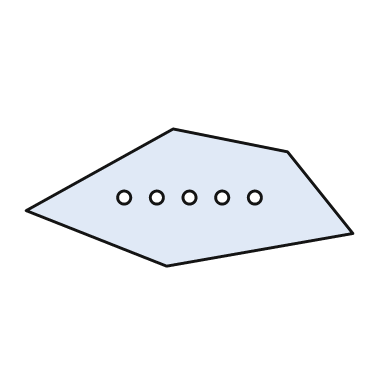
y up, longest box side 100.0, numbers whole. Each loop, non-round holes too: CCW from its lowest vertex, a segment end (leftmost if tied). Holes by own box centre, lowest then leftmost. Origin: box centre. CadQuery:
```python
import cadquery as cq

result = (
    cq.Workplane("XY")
    .moveTo(-7.0, -21.0)
    .lineTo(50.0, -11.0)
    .lineTo(30.0, 14.0)
    .lineTo(-5.0, 21.0)
    .lineTo(-50.0, -4.0)
    .close()
    .moveTo(-20.0, 0.0)
    .circle(2.0)
    .moveTo(-10.0, 0.0)
    .circle(2.0)
    .moveTo(0.0, 0.0)
    .circle(2.0)
    .moveTo(10.0, 0.0)
    .circle(2.0)
    .moveTo(20.0, 0.0)
    .circle(2.0)
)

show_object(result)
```